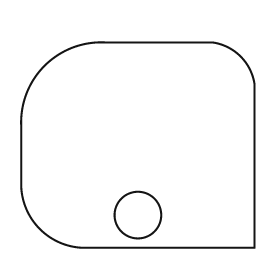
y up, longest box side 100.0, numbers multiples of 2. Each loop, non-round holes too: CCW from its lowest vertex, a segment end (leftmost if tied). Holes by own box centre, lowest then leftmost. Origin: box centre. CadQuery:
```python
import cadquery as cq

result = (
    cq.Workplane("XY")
    .moveTo(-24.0, -44.0)
    .lineTo(50.0, -44.0)
    .lineTo(50.0, 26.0)
    .threePointArc((44.0, 38.0), (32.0, 44.0))
    .lineTo(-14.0, 44.0)
    .threePointArc((-40.0, 34.0), (-50.0, 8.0))
    .lineTo(-50.0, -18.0)
    .threePointArc((-42.0, -36.0), (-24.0, -44.0))
    .close()
    .moveTo(0.0, -30.0)
    .circle(10.0)
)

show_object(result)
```